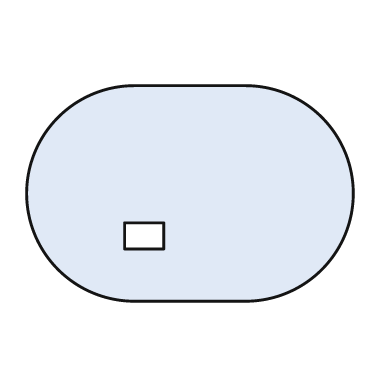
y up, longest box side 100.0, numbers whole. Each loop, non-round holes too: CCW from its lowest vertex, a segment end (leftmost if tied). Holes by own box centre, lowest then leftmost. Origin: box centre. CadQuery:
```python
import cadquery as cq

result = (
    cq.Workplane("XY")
    .moveTo(-17.0, -33.0)
    .lineTo(17.0, -33.0)
    .threePointArc((50.0, 0.0), (17.0, 33.0))
    .lineTo(-17.0, 33.0)
    .threePointArc((-50.0, 0.0), (-17.0, -33.0))
    .close()
    .moveTo(-20.0, -17.0)
    .lineTo(-8.0, -17.0)
    .lineTo(-8.0, -9.0)
    .lineTo(-20.0, -9.0)
    .close()
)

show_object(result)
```